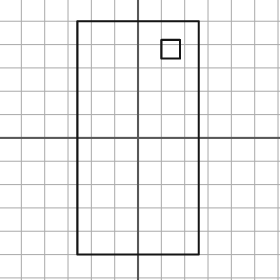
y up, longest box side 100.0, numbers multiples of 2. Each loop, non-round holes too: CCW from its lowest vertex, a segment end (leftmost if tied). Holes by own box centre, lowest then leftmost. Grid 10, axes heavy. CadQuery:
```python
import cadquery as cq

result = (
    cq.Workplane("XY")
    .moveTo(-26.0, -50.0)
    .lineTo(26.0, -50.0)
    .lineTo(26.0, 50.0)
    .lineTo(-26.0, 50.0)
    .close()
    .moveTo(10.0, 34.0)
    .lineTo(18.0, 34.0)
    .lineTo(18.0, 42.0)
    .lineTo(10.0, 42.0)
    .close()
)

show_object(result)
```